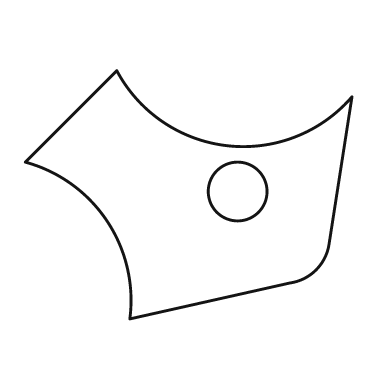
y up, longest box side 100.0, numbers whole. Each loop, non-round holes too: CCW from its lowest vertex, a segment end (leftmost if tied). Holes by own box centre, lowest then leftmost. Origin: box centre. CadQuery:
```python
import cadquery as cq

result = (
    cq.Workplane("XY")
    .moveTo(-18.0, -38.0)
    .lineTo(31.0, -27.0)
    .threePointArc((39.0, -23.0), (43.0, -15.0))
    .lineTo(50.0, 30.0)
    .threePointArc((12.0, 15.0), (-22.0, 38.0))
    .lineTo(-50.0, 10.0)
    .threePointArc((-25.0, -8.0), (-18.0, -38.0))
    .close()
    .moveTo(15.0, 1.0)
    .circle(9.0)
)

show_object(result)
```